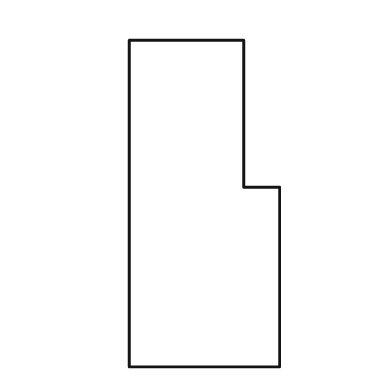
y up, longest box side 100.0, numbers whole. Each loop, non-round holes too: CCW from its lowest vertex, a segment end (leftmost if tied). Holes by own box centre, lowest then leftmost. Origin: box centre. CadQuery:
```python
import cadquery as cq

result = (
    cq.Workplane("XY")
    .moveTo(-23.0, -50.0)
    .lineTo(23.0, -50.0)
    .lineTo(23.0, 5.0)
    .lineTo(12.0, 5.0)
    .lineTo(12.0, 50.0)
    .lineTo(-23.0, 50.0)
    .close()
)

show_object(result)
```